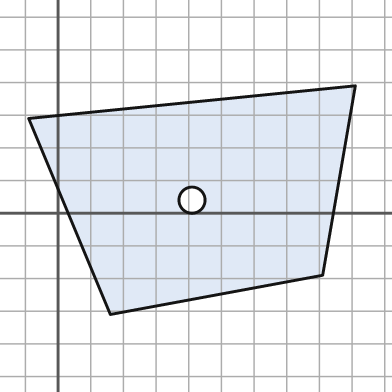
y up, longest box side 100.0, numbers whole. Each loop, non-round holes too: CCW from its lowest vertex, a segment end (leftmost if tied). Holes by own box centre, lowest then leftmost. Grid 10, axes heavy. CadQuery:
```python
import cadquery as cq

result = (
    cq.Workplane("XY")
    .moveTo(16.0, -31.0)
    .lineTo(81.0, -19.0)
    .lineTo(91.0, 39.0)
    .lineTo(-9.0, 29.0)
    .close()
    .moveTo(41.0, 4.0)
    .circle(4.0)
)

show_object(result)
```